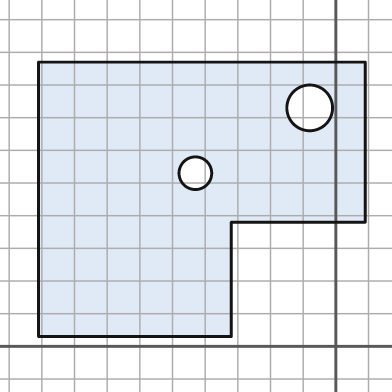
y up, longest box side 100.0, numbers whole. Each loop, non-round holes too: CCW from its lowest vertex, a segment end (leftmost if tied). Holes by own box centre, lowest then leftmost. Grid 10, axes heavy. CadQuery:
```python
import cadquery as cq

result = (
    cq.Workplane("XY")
    .moveTo(-91.0, 3.0)
    .lineTo(-32.0, 3.0)
    .lineTo(-32.0, 38.0)
    .lineTo(9.0, 38.0)
    .lineTo(9.0, 87.0)
    .lineTo(-91.0, 87.0)
    .close()
    .moveTo(-43.0, 53.0)
    .circle(5.0)
    .moveTo(-8.0, 73.0)
    .circle(7.0)
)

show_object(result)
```